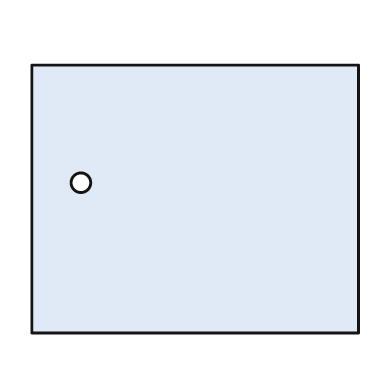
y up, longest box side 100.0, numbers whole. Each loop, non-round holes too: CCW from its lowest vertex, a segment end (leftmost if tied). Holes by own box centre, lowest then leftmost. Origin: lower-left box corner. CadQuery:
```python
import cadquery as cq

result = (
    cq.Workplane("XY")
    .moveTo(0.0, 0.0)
    .lineTo(100.0, 0.0)
    .lineTo(100.0, 82.0)
    .lineTo(0.0, 82.0)
    .close()
    .moveTo(15.0, 46.0)
    .circle(3.0)
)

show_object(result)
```